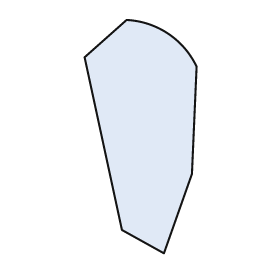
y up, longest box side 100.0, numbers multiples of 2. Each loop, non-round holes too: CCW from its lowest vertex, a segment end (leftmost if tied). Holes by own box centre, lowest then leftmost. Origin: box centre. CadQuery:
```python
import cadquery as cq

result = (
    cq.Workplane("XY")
    .moveTo(10.0, -50.0)
    .lineTo(22.0, -16.0)
    .lineTo(24.0, 30.0)
    .threePointArc((12.0, 44.0), (-6.0, 50.0))
    .lineTo(-24.0, 34.0)
    .lineTo(-8.0, -40.0)
    .close()
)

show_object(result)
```